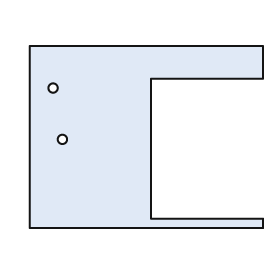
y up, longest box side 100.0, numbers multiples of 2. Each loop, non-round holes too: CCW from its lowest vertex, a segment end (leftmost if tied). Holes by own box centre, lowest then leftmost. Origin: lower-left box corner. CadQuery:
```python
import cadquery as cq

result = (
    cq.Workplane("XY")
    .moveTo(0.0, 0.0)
    .lineTo(100.0, 0.0)
    .lineTo(100.0, 4.0)
    .lineTo(52.0, 4.0)
    .lineTo(52.0, 64.0)
    .lineTo(100.0, 64.0)
    .lineTo(100.0, 78.0)
    .lineTo(0.0, 78.0)
    .close()
    .moveTo(14.0, 38.0)
    .circle(2.0)
    .moveTo(10.0, 60.0)
    .circle(2.0)
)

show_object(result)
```